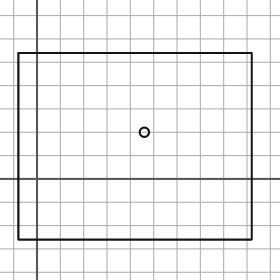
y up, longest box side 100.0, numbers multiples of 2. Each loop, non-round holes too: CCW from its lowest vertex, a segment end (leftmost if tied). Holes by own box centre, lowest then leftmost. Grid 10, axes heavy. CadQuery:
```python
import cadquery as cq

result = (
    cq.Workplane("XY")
    .moveTo(-8.0, -26.0)
    .lineTo(92.0, -26.0)
    .lineTo(92.0, 54.0)
    .lineTo(-8.0, 54.0)
    .close()
    .moveTo(46.0, 20.0)
    .circle(2.0)
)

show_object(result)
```